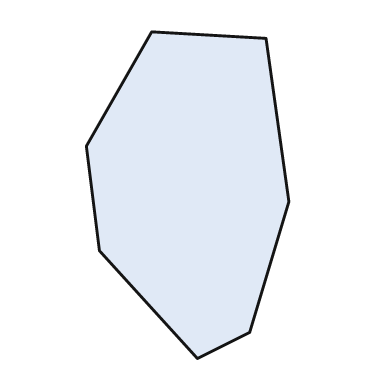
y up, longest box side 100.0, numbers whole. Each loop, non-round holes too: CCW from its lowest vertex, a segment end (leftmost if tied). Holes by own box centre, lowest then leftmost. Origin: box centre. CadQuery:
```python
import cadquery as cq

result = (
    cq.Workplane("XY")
    .moveTo(3.0, -50.0)
    .lineTo(19.0, -42.0)
    .lineTo(31.0, -2.0)
    .lineTo(24.0, 48.0)
    .lineTo(-11.0, 50.0)
    .lineTo(-31.0, 15.0)
    .lineTo(-27.0, -17.0)
    .close()
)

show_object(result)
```